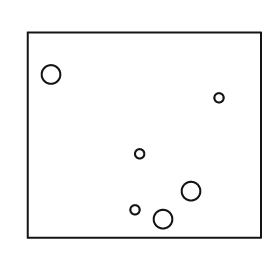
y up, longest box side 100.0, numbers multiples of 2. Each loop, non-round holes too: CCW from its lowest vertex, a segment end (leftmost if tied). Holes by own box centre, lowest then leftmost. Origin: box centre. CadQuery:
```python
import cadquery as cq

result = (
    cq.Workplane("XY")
    .moveTo(-50.0, -44.0)
    .lineTo(50.0, -44.0)
    .lineTo(50.0, 44.0)
    .lineTo(-50.0, 44.0)
    .close()
    .moveTo(8.0, -36.0)
    .circle(4.0)
    .moveTo(-4.0, -32.0)
    .circle(2.0)
    .moveTo(20.0, -24.0)
    .circle(4.0)
    .moveTo(-2.0, -8.0)
    .circle(2.0)
    .moveTo(32.0, 16.0)
    .circle(2.0)
    .moveTo(-40.0, 26.0)
    .circle(4.0)
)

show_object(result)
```